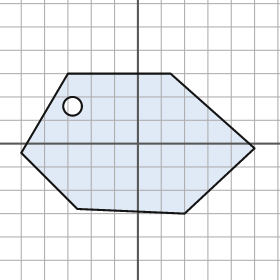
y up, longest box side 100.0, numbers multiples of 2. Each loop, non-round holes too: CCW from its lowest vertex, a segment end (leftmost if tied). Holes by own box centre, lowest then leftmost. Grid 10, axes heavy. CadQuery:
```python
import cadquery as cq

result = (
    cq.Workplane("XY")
    .moveTo(20.0, -30.0)
    .lineTo(50.0, -2.0)
    .lineTo(14.0, 30.0)
    .lineTo(-30.0, 30.0)
    .lineTo(-50.0, -4.0)
    .lineTo(-26.0, -28.0)
    .close()
    .moveTo(-28.0, 16.0)
    .circle(4.0)
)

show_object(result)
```